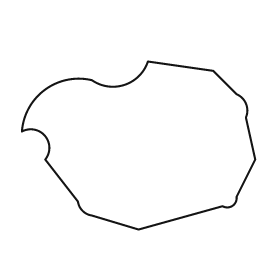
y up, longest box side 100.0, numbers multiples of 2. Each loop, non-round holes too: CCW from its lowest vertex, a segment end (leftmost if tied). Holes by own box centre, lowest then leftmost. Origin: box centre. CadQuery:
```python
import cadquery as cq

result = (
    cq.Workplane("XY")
    .moveTo(0.0, -36.0)
    .lineTo(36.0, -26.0)
    .threePointArc((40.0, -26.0), (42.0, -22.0))
    .lineTo(50.0, -6.0)
    .lineTo(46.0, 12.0)
    .threePointArc((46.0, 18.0), (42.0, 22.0))
    .lineTo(32.0, 32.0)
    .lineTo(4.0, 36.0)
    .threePointArc((-6.0, 26.0), (-20.0, 28.0))
    .threePointArc((-40.0, 24.0), (-50.0, 6.0))
    .threePointArc((-40.0, 4.0), (-40.0, -6.0))
    .lineTo(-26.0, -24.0)
    .threePointArc((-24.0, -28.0), (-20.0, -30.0))
    .close()
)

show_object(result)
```